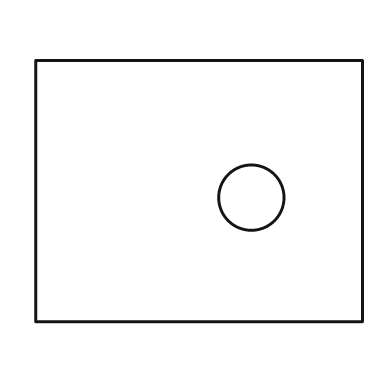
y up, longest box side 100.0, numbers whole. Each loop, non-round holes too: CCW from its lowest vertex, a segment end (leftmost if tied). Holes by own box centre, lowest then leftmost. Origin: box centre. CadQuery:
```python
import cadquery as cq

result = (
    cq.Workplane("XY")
    .moveTo(-50.0, -40.0)
    .lineTo(50.0, -40.0)
    .lineTo(50.0, 40.0)
    .lineTo(-50.0, 40.0)
    .close()
    .moveTo(16.0, -2.0)
    .circle(10.0)
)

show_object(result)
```